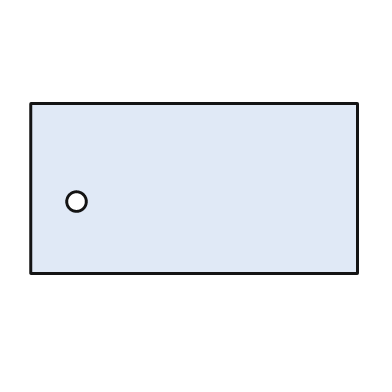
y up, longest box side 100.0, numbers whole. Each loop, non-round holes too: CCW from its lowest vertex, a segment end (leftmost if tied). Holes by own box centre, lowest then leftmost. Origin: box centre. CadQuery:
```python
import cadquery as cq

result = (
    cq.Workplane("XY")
    .moveTo(-50.0, -26.0)
    .lineTo(50.0, -26.0)
    .lineTo(50.0, 26.0)
    .lineTo(-50.0, 26.0)
    .close()
    .moveTo(-36.0, -4.0)
    .circle(3.0)
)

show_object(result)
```